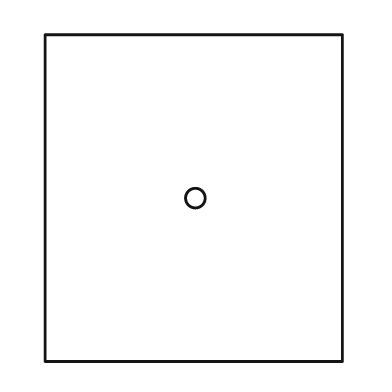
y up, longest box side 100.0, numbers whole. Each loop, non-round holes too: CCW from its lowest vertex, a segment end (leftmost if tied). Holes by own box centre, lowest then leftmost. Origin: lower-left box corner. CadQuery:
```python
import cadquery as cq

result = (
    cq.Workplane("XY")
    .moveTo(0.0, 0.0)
    .lineTo(91.0, 0.0)
    .lineTo(91.0, 100.0)
    .lineTo(0.0, 100.0)
    .close()
    .moveTo(46.0, 50.0)
    .circle(3.0)
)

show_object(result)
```